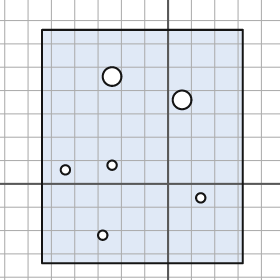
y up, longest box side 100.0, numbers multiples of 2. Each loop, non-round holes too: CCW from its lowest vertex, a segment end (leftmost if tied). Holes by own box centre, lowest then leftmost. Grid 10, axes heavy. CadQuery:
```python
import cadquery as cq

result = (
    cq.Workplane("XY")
    .moveTo(-54.0, -34.0)
    .lineTo(32.0, -34.0)
    .lineTo(32.0, 66.0)
    .lineTo(-54.0, 66.0)
    .close()
    .moveTo(-28.0, -22.0)
    .circle(2.0)
    .moveTo(14.0, -6.0)
    .circle(2.0)
    .moveTo(-44.0, 6.0)
    .circle(2.0)
    .moveTo(-24.0, 8.0)
    .circle(2.0)
    .moveTo(6.0, 36.0)
    .circle(4.0)
    .moveTo(-24.0, 46.0)
    .circle(4.0)
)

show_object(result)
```